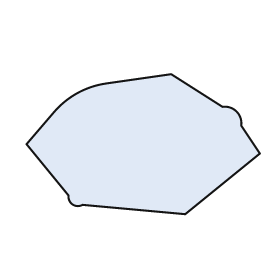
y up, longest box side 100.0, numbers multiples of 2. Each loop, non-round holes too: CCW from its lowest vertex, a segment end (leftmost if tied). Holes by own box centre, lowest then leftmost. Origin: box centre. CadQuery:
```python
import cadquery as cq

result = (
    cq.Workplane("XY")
    .moveTo(18.0, -30.0)
    .lineTo(50.0, -4.0)
    .lineTo(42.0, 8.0)
    .threePointArc((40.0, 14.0), (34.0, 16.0))
    .lineTo(12.0, 30.0)
    .lineTo(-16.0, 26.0)
    .threePointArc((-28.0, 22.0), (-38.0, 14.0))
    .lineTo(-50.0, 0.0)
    .lineTo(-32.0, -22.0)
    .threePointArc((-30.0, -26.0), (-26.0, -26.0))
    .close()
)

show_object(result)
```